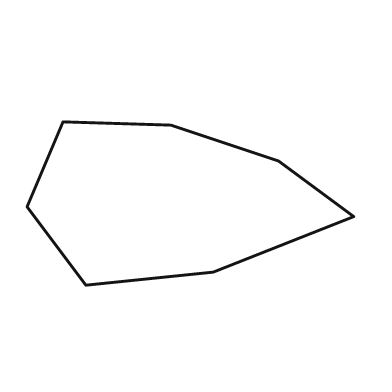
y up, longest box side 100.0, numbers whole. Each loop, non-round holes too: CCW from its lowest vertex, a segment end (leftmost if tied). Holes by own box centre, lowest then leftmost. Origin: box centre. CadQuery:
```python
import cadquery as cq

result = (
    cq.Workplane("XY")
    .moveTo(-32.0, -25.0)
    .lineTo(7.0, -21.0)
    .lineTo(50.0, -4.0)
    .lineTo(27.0, 13.0)
    .lineTo(-6.0, 24.0)
    .lineTo(-39.0, 25.0)
    .lineTo(-50.0, -1.0)
    .close()
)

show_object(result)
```